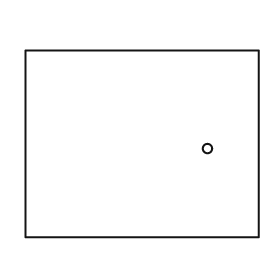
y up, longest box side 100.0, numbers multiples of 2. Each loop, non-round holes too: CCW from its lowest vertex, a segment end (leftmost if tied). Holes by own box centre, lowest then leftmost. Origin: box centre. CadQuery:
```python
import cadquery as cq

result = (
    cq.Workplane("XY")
    .moveTo(-50.0, -40.0)
    .lineTo(50.0, -40.0)
    .lineTo(50.0, 40.0)
    .lineTo(-50.0, 40.0)
    .close()
    .moveTo(28.0, -2.0)
    .circle(2.0)
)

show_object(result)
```